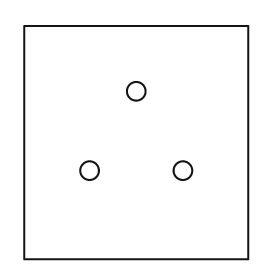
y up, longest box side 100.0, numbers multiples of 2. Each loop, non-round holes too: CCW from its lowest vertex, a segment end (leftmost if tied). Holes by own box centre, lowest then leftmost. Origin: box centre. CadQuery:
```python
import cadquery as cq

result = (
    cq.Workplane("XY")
    .moveTo(-48.0, -50.0)
    .lineTo(48.0, -50.0)
    .lineTo(48.0, 50.0)
    .lineTo(-48.0, 50.0)
    .close()
    .moveTo(-20.0, -12.0)
    .circle(4.0)
    .moveTo(20.0, -12.0)
    .circle(4.0)
    .moveTo(0.0, 22.0)
    .circle(4.0)
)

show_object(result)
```